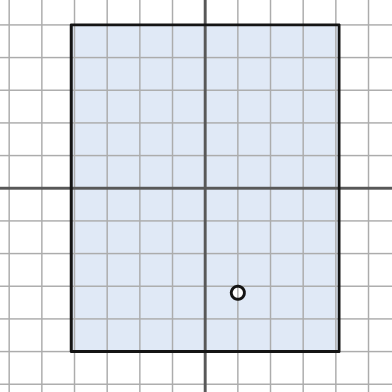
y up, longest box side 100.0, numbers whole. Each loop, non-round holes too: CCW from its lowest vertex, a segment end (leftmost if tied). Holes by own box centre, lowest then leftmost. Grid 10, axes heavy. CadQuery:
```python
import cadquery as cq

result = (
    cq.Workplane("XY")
    .moveTo(-41.0, -50.0)
    .lineTo(41.0, -50.0)
    .lineTo(41.0, 50.0)
    .lineTo(-41.0, 50.0)
    .close()
    .moveTo(10.0, -32.0)
    .circle(2.0)
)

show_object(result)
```